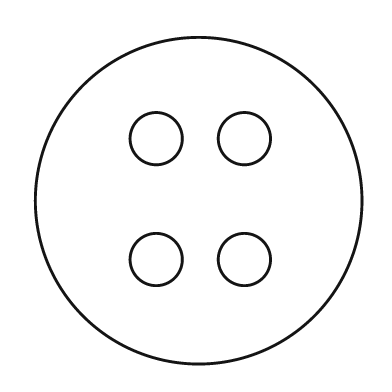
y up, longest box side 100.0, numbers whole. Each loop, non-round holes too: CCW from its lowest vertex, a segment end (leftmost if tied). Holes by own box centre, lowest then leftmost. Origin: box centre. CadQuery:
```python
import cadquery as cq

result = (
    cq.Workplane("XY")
    .moveTo(0.0, 0.0)
    .circle(50.0)
    .moveTo(-13.0, -18.0)
    .circle(8.0)
    .moveTo(14.0, -18.0)
    .circle(8.0)
    .moveTo(-13.0, 19.0)
    .circle(8.0)
    .moveTo(14.0, 19.0)
    .circle(8.0)
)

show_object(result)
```